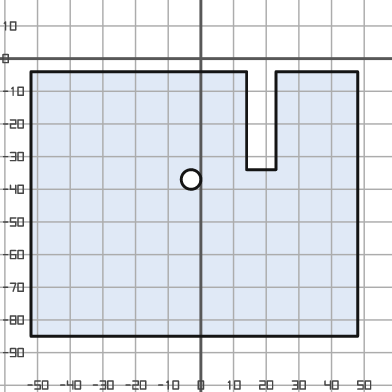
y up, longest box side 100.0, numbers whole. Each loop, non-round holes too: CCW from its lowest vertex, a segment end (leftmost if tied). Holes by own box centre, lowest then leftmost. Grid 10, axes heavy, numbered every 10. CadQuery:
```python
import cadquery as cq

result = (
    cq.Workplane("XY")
    .moveTo(-52.0, -85.0)
    .lineTo(48.0, -85.0)
    .lineTo(48.0, -4.0)
    .lineTo(23.0, -4.0)
    .lineTo(23.0, -34.0)
    .lineTo(14.0, -34.0)
    .lineTo(14.0, -4.0)
    .lineTo(-52.0, -4.0)
    .close()
    .moveTo(-3.0, -37.0)
    .circle(3.0)
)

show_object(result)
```